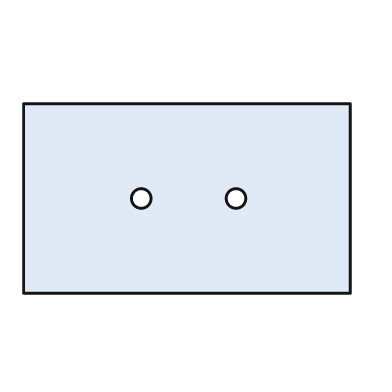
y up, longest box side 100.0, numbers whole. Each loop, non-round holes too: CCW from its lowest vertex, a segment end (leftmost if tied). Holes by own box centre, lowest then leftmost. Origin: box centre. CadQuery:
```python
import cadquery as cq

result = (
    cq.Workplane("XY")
    .moveTo(-50.0, -29.0)
    .lineTo(50.0, -29.0)
    .lineTo(50.0, 29.0)
    .lineTo(-50.0, 29.0)
    .close()
    .moveTo(-14.0, 0.0)
    .circle(3.0)
    .moveTo(15.0, 0.0)
    .circle(3.0)
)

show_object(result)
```